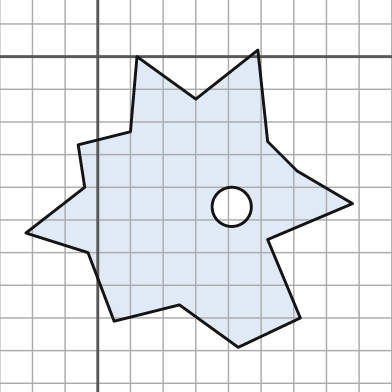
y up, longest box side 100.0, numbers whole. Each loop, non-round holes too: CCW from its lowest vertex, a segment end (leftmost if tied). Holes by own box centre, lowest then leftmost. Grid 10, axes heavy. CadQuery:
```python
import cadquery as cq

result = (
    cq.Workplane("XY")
    .moveTo(43.0, -89.0)
    .lineTo(62.0, -80.0)
    .lineTo(52.0, -56.0)
    .lineTo(78.0, -45.0)
    .lineTo(61.0, -35.0)
    .lineTo(52.0, -26.0)
    .lineTo(49.0, 2.0)
    .lineTo(30.0, -13.0)
    .lineTo(12.0, 0.0)
    .lineTo(10.0, -23.0)
    .lineTo(-6.0, -27.0)
    .lineTo(-4.0, -40.0)
    .lineTo(-22.0, -54.0)
    .lineTo(-3.0, -60.0)
    .lineTo(5.0, -81.0)
    .lineTo(25.0, -76.0)
    .close()
    .moveTo(41.0, -46.0)
    .circle(6.0)
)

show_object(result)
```